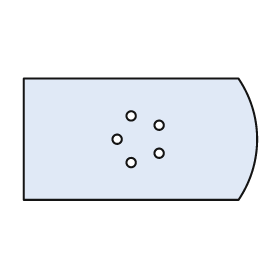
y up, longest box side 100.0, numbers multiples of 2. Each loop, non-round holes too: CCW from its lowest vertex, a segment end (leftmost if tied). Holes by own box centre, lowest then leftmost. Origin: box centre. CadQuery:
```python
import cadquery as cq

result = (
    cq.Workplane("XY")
    .moveTo(-50.0, -26.0)
    .lineTo(42.0, -26.0)
    .threePointArc((50.0, 0.0), (42.0, 26.0))
    .lineTo(-50.0, 26.0)
    .close()
    .moveTo(-4.0, -10.0)
    .circle(2.0)
    .moveTo(8.0, -6.0)
    .circle(2.0)
    .moveTo(-10.0, 0.0)
    .circle(2.0)
    .moveTo(8.0, 6.0)
    .circle(2.0)
    .moveTo(-4.0, 10.0)
    .circle(2.0)
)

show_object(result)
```